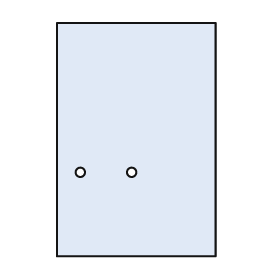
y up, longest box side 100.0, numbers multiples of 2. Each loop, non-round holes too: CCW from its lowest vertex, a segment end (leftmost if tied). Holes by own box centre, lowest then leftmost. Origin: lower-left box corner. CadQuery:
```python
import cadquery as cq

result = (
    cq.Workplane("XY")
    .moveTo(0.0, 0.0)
    .lineTo(68.0, 0.0)
    .lineTo(68.0, 100.0)
    .lineTo(0.0, 100.0)
    .close()
    .moveTo(10.0, 36.0)
    .circle(2.0)
    .moveTo(32.0, 36.0)
    .circle(2.0)
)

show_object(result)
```